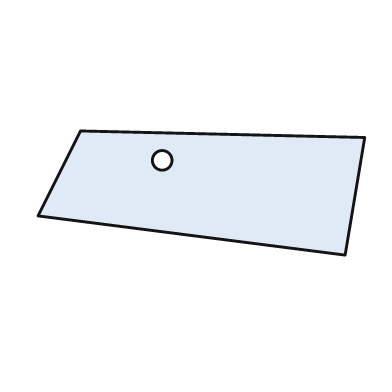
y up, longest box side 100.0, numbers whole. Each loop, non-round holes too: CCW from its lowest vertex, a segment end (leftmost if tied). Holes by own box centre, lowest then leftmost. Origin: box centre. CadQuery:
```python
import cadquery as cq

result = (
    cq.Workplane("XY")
    .moveTo(44.0, -19.0)
    .lineTo(50.0, 17.0)
    .lineTo(-37.0, 19.0)
    .lineTo(-50.0, -7.0)
    .close()
    .moveTo(-12.0, 10.0)
    .circle(3.0)
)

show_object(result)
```